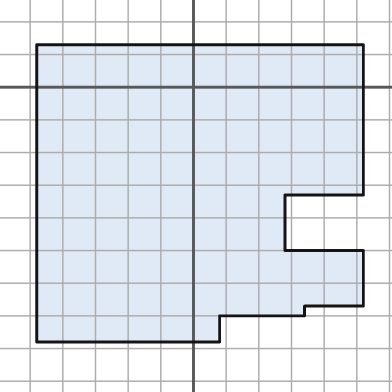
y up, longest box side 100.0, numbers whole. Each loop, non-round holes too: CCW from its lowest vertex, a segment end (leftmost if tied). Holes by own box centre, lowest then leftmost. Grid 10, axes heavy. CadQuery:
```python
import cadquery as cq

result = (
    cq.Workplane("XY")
    .moveTo(-48.0, -78.0)
    .lineTo(8.0, -78.0)
    .lineTo(8.0, -70.0)
    .lineTo(34.0, -70.0)
    .lineTo(34.0, -67.0)
    .lineTo(52.0, -67.0)
    .lineTo(52.0, -50.0)
    .lineTo(28.0, -50.0)
    .lineTo(28.0, -33.0)
    .lineTo(52.0, -33.0)
    .lineTo(52.0, 13.0)
    .lineTo(-48.0, 13.0)
    .close()
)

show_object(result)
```